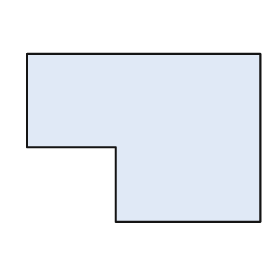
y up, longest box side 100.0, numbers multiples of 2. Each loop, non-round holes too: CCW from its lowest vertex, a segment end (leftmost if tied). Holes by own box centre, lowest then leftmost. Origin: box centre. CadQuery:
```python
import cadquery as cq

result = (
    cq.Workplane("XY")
    .moveTo(-12.0, -36.0)
    .lineTo(50.0, -36.0)
    .lineTo(50.0, 36.0)
    .lineTo(-50.0, 36.0)
    .lineTo(-50.0, -4.0)
    .lineTo(-12.0, -4.0)
    .close()
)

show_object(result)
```